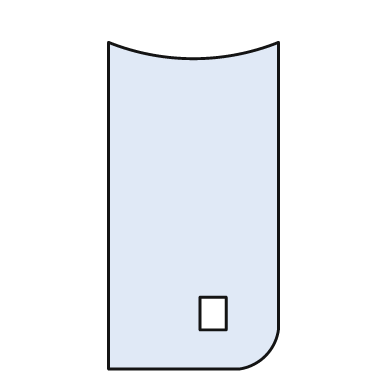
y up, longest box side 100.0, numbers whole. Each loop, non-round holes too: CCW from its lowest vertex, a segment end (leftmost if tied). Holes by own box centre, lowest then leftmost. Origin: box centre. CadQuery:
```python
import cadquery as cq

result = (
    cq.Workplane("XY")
    .moveTo(-26.0, -50.0)
    .lineTo(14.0, -50.0)
    .threePointArc((22.0, -46.0), (26.0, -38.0))
    .lineTo(26.0, 50.0)
    .threePointArc((0.0, 45.0), (-26.0, 50.0))
    .close()
    .moveTo(2.0, -38.0)
    .lineTo(10.0, -38.0)
    .lineTo(10.0, -28.0)
    .lineTo(2.0, -28.0)
    .close()
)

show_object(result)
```